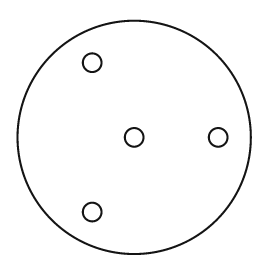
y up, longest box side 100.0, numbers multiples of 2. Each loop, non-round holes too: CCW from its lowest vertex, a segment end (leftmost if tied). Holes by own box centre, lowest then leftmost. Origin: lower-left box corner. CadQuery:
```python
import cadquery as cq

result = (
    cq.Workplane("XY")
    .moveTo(50.0, 50.0)
    .circle(50.0)
    .moveTo(32.0, 18.0)
    .circle(4.0)
    .moveTo(50.0, 50.0)
    .circle(4.0)
    .moveTo(86.0, 50.0)
    .circle(4.0)
    .moveTo(32.0, 82.0)
    .circle(4.0)
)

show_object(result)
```